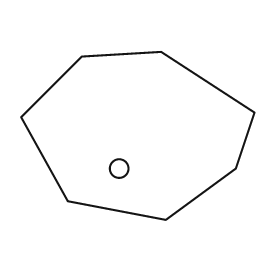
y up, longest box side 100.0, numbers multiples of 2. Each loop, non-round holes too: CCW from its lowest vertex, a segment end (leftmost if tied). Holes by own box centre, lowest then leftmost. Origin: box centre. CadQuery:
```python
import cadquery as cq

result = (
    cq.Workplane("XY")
    .moveTo(12.0, -36.0)
    .lineTo(42.0, -14.0)
    .lineTo(50.0, 10.0)
    .lineTo(10.0, 36.0)
    .lineTo(-24.0, 34.0)
    .lineTo(-50.0, 8.0)
    .lineTo(-30.0, -28.0)
    .close()
    .moveTo(-8.0, -14.0)
    .circle(4.0)
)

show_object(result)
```